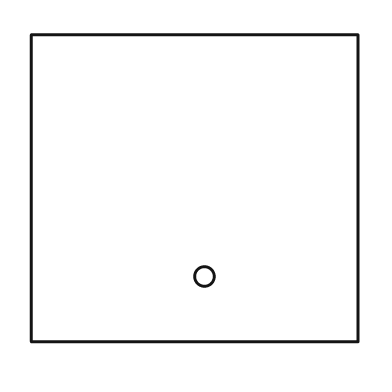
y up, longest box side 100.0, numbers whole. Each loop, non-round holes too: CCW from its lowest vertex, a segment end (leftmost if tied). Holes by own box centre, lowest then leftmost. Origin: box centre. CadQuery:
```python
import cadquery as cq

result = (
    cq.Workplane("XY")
    .moveTo(-50.0, -47.0)
    .lineTo(50.0, -47.0)
    .lineTo(50.0, 47.0)
    .lineTo(-50.0, 47.0)
    .close()
    .moveTo(3.0, -27.0)
    .circle(3.0)
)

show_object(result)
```